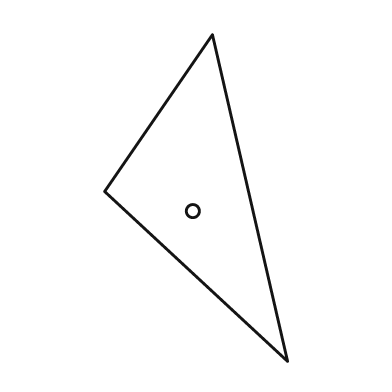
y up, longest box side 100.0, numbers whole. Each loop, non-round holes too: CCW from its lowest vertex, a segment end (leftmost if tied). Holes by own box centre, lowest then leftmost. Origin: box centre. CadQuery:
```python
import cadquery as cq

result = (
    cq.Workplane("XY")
    .moveTo(28.0, -50.0)
    .lineTo(5.0, 50.0)
    .lineTo(-28.0, 2.0)
    .close()
    .moveTo(-1.0, -4.0)
    .circle(2.0)
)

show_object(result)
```